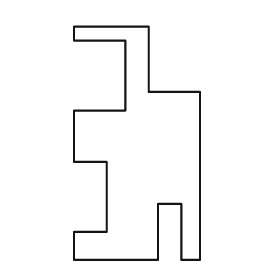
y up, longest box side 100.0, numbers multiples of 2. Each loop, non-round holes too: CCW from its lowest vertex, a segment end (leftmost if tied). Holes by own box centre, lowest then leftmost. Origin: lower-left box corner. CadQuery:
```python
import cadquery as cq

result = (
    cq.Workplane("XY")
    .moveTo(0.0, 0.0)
    .lineTo(36.0, 0.0)
    .lineTo(36.0, 24.0)
    .lineTo(46.0, 24.0)
    .lineTo(46.0, 0.0)
    .lineTo(54.0, 0.0)
    .lineTo(54.0, 72.0)
    .lineTo(32.0, 72.0)
    .lineTo(32.0, 100.0)
    .lineTo(0.0, 100.0)
    .lineTo(0.0, 94.0)
    .lineTo(22.0, 94.0)
    .lineTo(22.0, 64.0)
    .lineTo(0.0, 64.0)
    .lineTo(0.0, 42.0)
    .lineTo(14.0, 42.0)
    .lineTo(14.0, 12.0)
    .lineTo(0.0, 12.0)
    .close()
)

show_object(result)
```